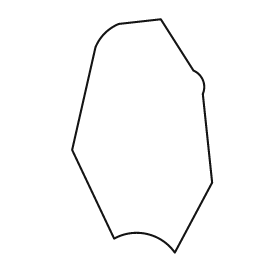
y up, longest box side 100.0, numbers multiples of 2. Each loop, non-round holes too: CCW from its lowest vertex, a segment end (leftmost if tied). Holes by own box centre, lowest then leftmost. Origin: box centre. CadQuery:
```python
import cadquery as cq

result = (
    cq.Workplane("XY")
    .moveTo(14.0, -50.0)
    .lineTo(30.0, -20.0)
    .lineTo(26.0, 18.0)
    .threePointArc((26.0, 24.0), (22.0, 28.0))
    .lineTo(8.0, 50.0)
    .lineTo(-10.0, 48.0)
    .threePointArc((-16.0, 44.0), (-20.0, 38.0))
    .lineTo(-30.0, -6.0)
    .lineTo(-12.0, -44.0)
    .threePointArc((2.0, -42.0), (14.0, -50.0))
    .close()
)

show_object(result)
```